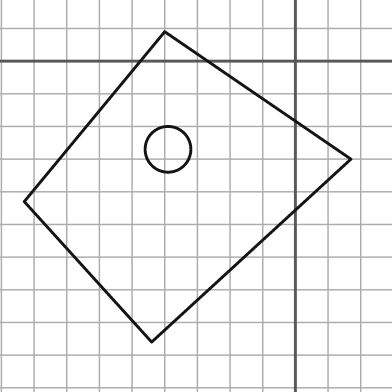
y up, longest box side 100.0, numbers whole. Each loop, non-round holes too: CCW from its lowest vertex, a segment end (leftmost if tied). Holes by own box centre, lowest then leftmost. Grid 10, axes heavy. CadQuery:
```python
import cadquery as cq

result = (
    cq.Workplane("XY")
    .moveTo(-44.0, -86.0)
    .lineTo(17.0, -30.0)
    .lineTo(-40.0, 9.0)
    .lineTo(-83.0, -43.0)
    .close()
    .moveTo(-39.0, -27.0)
    .circle(7.0)
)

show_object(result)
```